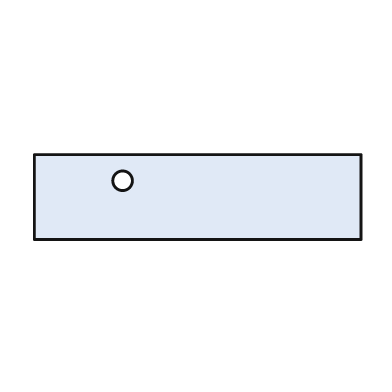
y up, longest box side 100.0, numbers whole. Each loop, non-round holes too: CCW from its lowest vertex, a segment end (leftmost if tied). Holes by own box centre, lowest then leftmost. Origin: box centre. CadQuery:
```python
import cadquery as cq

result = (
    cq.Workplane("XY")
    .moveTo(-50.0, -13.0)
    .lineTo(50.0, -13.0)
    .lineTo(50.0, 13.0)
    .lineTo(-50.0, 13.0)
    .close()
    .moveTo(-23.0, 5.0)
    .circle(3.0)
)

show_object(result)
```